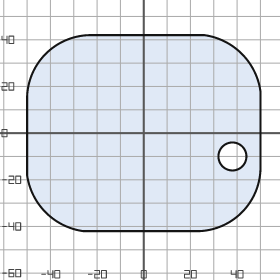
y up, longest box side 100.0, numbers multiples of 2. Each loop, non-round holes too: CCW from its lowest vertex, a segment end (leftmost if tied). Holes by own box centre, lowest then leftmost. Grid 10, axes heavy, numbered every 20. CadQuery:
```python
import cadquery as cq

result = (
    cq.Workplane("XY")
    .moveTo(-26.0, -42.0)
    .lineTo(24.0, -42.0)
    .threePointArc((42.0, -34.0), (50.0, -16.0))
    .lineTo(50.0, 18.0)
    .threePointArc((42.0, 34.0), (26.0, 42.0))
    .lineTo(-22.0, 42.0)
    .threePointArc((-42.0, 34.0), (-50.0, 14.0))
    .lineTo(-50.0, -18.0)
    .threePointArc((-42.0, -34.0), (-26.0, -42.0))
    .close()
    .moveTo(38.0, -10.0)
    .circle(6.0)
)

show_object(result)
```